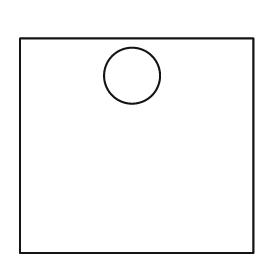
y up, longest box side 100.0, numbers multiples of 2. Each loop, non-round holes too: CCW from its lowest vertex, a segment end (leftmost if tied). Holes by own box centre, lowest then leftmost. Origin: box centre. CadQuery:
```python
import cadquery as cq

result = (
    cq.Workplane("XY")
    .moveTo(-50.0, -46.0)
    .lineTo(50.0, -46.0)
    .lineTo(50.0, 46.0)
    .lineTo(-50.0, 46.0)
    .close()
    .moveTo(-2.0, 30.0)
    .circle(12.0)
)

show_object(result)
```